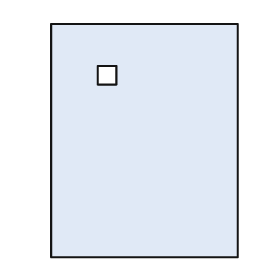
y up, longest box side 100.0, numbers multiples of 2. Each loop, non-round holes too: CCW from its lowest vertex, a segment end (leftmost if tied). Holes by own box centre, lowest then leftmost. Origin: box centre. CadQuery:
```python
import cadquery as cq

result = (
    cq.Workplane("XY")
    .moveTo(-40.0, -50.0)
    .lineTo(40.0, -50.0)
    .lineTo(40.0, 50.0)
    .lineTo(-40.0, 50.0)
    .close()
    .moveTo(-20.0, 24.0)
    .lineTo(-12.0, 24.0)
    .lineTo(-12.0, 32.0)
    .lineTo(-20.0, 32.0)
    .close()
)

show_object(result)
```